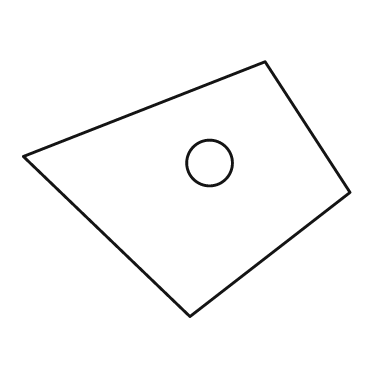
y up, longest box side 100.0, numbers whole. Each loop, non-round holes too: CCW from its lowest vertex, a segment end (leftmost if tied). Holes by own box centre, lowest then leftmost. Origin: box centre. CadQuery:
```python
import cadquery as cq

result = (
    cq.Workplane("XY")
    .moveTo(1.0, -39.0)
    .lineTo(50.0, -1.0)
    .lineTo(24.0, 39.0)
    .lineTo(-50.0, 10.0)
    .close()
    .moveTo(7.0, 8.0)
    .circle(7.0)
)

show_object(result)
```